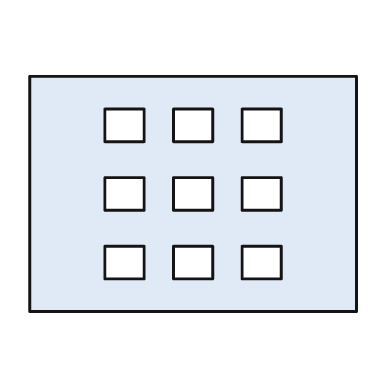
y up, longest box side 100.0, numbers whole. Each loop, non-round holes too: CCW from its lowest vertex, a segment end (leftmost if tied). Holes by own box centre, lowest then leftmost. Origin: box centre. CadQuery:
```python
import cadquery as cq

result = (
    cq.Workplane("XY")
    .moveTo(-50.0, -36.0)
    .lineTo(50.0, -36.0)
    .lineTo(50.0, 36.0)
    .lineTo(-50.0, 36.0)
    .close()
    .moveTo(-27.0, -26.0)
    .lineTo(-15.0, -26.0)
    .lineTo(-15.0, -16.0)
    .lineTo(-27.0, -16.0)
    .close()
    .moveTo(-6.0, -26.0)
    .lineTo(6.0, -26.0)
    .lineTo(6.0, -16.0)
    .lineTo(-6.0, -16.0)
    .close()
    .moveTo(15.0, -26.0)
    .lineTo(27.0, -26.0)
    .lineTo(27.0, -16.0)
    .lineTo(15.0, -16.0)
    .close()
    .moveTo(-27.0, -5.0)
    .lineTo(-15.0, -5.0)
    .lineTo(-15.0, 5.0)
    .lineTo(-27.0, 5.0)
    .close()
    .moveTo(-6.0, -5.0)
    .lineTo(6.0, -5.0)
    .lineTo(6.0, 5.0)
    .lineTo(-6.0, 5.0)
    .close()
    .moveTo(15.0, -5.0)
    .lineTo(27.0, -5.0)
    .lineTo(27.0, 5.0)
    .lineTo(15.0, 5.0)
    .close()
    .moveTo(-27.0, 16.0)
    .lineTo(-15.0, 16.0)
    .lineTo(-15.0, 26.0)
    .lineTo(-27.0, 26.0)
    .close()
    .moveTo(-6.0, 16.0)
    .lineTo(6.0, 16.0)
    .lineTo(6.0, 26.0)
    .lineTo(-6.0, 26.0)
    .close()
    .moveTo(15.0, 16.0)
    .lineTo(27.0, 16.0)
    .lineTo(27.0, 26.0)
    .lineTo(15.0, 26.0)
    .close()
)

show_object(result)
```